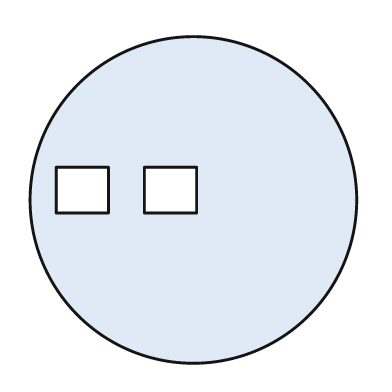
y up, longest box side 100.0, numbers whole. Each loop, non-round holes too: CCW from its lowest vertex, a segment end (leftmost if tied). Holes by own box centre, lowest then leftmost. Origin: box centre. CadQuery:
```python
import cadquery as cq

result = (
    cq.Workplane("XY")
    .moveTo(0.0, 0.0)
    .circle(50.0)
    .moveTo(-42.0, -4.0)
    .lineTo(-26.0, -4.0)
    .lineTo(-26.0, 10.0)
    .lineTo(-42.0, 10.0)
    .close()
    .moveTo(-15.0, -4.0)
    .lineTo(1.0, -4.0)
    .lineTo(1.0, 10.0)
    .lineTo(-15.0, 10.0)
    .close()
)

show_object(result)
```